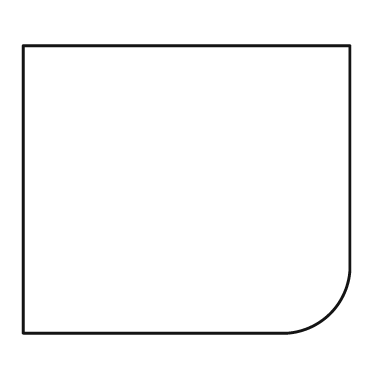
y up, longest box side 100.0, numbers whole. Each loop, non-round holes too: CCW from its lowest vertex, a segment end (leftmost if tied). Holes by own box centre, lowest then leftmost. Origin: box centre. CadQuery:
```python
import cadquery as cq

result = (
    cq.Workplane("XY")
    .moveTo(-50.0, -44.0)
    .lineTo(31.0, -44.0)
    .threePointArc((44.0, -38.0), (50.0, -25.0))
    .lineTo(50.0, 44.0)
    .lineTo(-50.0, 44.0)
    .close()
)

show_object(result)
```